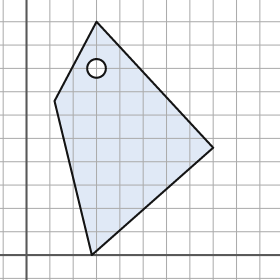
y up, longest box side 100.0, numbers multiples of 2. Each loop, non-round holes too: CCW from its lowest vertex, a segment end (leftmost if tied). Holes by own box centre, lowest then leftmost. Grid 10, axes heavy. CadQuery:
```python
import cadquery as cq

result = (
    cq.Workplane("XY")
    .moveTo(28.0, 0.0)
    .lineTo(80.0, 46.0)
    .lineTo(30.0, 100.0)
    .lineTo(12.0, 66.0)
    .close()
    .moveTo(30.0, 80.0)
    .circle(4.0)
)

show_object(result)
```